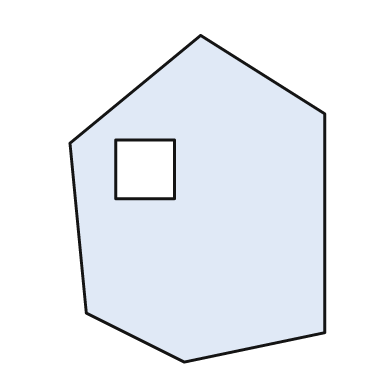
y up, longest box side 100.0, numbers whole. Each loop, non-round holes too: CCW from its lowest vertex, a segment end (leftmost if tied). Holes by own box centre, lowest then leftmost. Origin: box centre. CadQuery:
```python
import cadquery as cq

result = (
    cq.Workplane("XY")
    .moveTo(-4.0, -50.0)
    .lineTo(39.0, -41.0)
    .lineTo(39.0, 26.0)
    .lineTo(1.0, 50.0)
    .lineTo(-39.0, 17.0)
    .lineTo(-34.0, -35.0)
    .close()
    .moveTo(-25.0, 0.0)
    .lineTo(-7.0, 0.0)
    .lineTo(-7.0, 18.0)
    .lineTo(-25.0, 18.0)
    .close()
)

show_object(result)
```